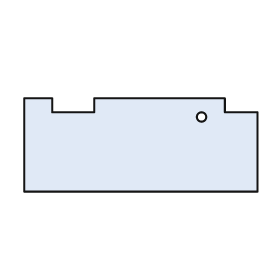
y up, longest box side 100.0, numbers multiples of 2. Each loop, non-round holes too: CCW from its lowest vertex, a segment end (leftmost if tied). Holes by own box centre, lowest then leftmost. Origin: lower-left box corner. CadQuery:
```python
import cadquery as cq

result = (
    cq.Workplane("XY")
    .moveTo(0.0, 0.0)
    .lineTo(100.0, 0.0)
    .lineTo(100.0, 34.0)
    .lineTo(86.0, 34.0)
    .lineTo(86.0, 40.0)
    .lineTo(30.0, 40.0)
    .lineTo(30.0, 34.0)
    .lineTo(12.0, 34.0)
    .lineTo(12.0, 40.0)
    .lineTo(0.0, 40.0)
    .close()
    .moveTo(76.0, 32.0)
    .circle(2.0)
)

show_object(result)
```